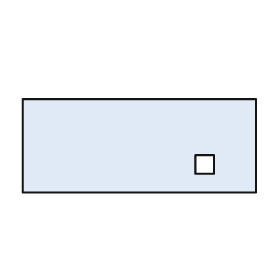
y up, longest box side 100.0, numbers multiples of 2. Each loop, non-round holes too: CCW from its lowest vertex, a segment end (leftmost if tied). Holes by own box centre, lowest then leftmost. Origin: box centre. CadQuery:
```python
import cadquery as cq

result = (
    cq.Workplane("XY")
    .moveTo(-50.0, -20.0)
    .lineTo(50.0, -20.0)
    .lineTo(50.0, 20.0)
    .lineTo(-50.0, 20.0)
    .close()
    .moveTo(24.0, -12.0)
    .lineTo(32.0, -12.0)
    .lineTo(32.0, -4.0)
    .lineTo(24.0, -4.0)
    .close()
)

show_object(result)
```